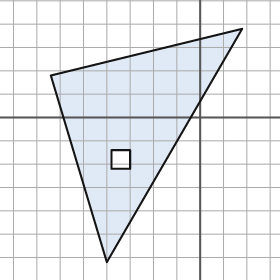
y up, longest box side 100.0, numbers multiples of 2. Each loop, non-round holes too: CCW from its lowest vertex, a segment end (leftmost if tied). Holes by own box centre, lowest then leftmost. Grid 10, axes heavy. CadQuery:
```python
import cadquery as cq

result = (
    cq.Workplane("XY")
    .moveTo(-40.0, -62.0)
    .lineTo(18.0, 38.0)
    .lineTo(-64.0, 18.0)
    .close()
    .moveTo(-38.0, -22.0)
    .lineTo(-30.0, -22.0)
    .lineTo(-30.0, -14.0)
    .lineTo(-38.0, -14.0)
    .close()
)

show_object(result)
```